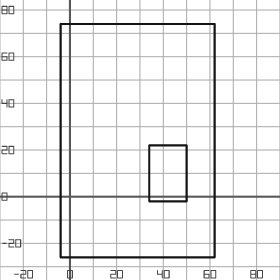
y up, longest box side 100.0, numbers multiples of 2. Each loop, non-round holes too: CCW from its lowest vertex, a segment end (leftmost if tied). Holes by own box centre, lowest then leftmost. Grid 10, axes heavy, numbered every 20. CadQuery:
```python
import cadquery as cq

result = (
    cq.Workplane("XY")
    .moveTo(-4.0, -26.0)
    .lineTo(62.0, -26.0)
    .lineTo(62.0, 74.0)
    .lineTo(-4.0, 74.0)
    .close()
    .moveTo(34.0, -2.0)
    .lineTo(50.0, -2.0)
    .lineTo(50.0, 22.0)
    .lineTo(34.0, 22.0)
    .close()
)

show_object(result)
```